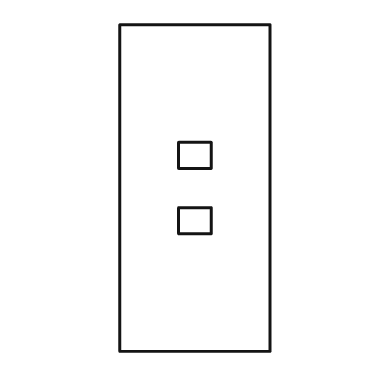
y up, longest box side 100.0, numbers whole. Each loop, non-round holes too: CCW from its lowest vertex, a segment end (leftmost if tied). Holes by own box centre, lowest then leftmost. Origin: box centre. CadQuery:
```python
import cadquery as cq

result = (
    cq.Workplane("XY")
    .moveTo(-23.0, -50.0)
    .lineTo(23.0, -50.0)
    .lineTo(23.0, 50.0)
    .lineTo(-23.0, 50.0)
    .close()
    .moveTo(-5.0, -14.0)
    .lineTo(5.0, -14.0)
    .lineTo(5.0, -6.0)
    .lineTo(-5.0, -6.0)
    .close()
    .moveTo(-5.0, 6.0)
    .lineTo(5.0, 6.0)
    .lineTo(5.0, 14.0)
    .lineTo(-5.0, 14.0)
    .close()
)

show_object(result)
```